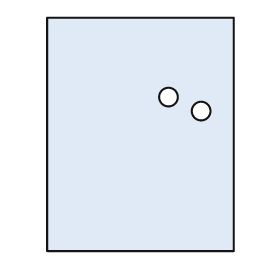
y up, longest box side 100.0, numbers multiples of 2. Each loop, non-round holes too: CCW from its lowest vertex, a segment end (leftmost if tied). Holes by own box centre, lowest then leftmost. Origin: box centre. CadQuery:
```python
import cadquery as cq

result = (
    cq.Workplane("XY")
    .moveTo(-40.0, -50.0)
    .lineTo(40.0, -50.0)
    .lineTo(40.0, 50.0)
    .lineTo(-40.0, 50.0)
    .close()
    .moveTo(26.0, 10.0)
    .circle(4.0)
    .moveTo(12.0, 16.0)
    .circle(4.0)
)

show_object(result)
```